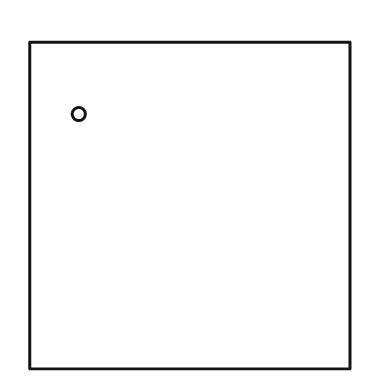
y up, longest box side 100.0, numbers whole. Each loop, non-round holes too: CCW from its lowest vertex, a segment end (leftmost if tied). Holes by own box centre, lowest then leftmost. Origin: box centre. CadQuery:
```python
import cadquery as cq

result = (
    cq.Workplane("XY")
    .moveTo(-49.0, -50.0)
    .lineTo(49.0, -50.0)
    .lineTo(49.0, 50.0)
    .lineTo(-49.0, 50.0)
    .close()
    .moveTo(-34.0, 28.0)
    .circle(2.0)
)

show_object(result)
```